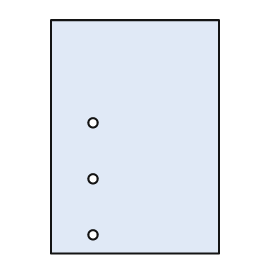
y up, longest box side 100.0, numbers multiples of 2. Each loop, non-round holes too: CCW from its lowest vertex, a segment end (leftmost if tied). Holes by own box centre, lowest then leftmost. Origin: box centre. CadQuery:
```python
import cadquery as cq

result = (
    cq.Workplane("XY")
    .moveTo(-36.0, -50.0)
    .lineTo(36.0, -50.0)
    .lineTo(36.0, 50.0)
    .lineTo(-36.0, 50.0)
    .close()
    .moveTo(-18.0, -42.0)
    .circle(2.0)
    .moveTo(-18.0, -18.0)
    .circle(2.0)
    .moveTo(-18.0, 6.0)
    .circle(2.0)
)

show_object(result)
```